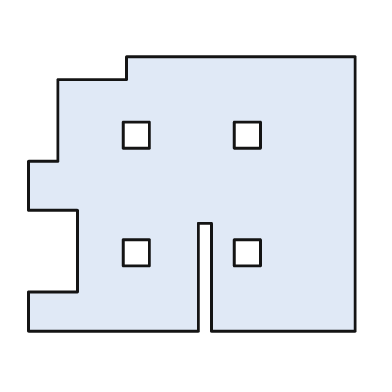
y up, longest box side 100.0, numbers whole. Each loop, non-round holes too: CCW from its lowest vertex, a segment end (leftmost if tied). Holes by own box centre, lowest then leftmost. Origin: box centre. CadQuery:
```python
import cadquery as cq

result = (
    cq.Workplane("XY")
    .moveTo(-50.0, -42.0)
    .lineTo(2.0, -42.0)
    .lineTo(2.0, -9.0)
    .lineTo(6.0, -9.0)
    .lineTo(6.0, -42.0)
    .lineTo(50.0, -42.0)
    .lineTo(50.0, 42.0)
    .lineTo(-20.0, 42.0)
    .lineTo(-20.0, 35.0)
    .lineTo(-41.0, 35.0)
    .lineTo(-41.0, 10.0)
    .lineTo(-50.0, 10.0)
    .lineTo(-50.0, -5.0)
    .lineTo(-35.0, -5.0)
    .lineTo(-35.0, -30.0)
    .lineTo(-50.0, -30.0)
    .close()
    .moveTo(-21.0, -22.0)
    .lineTo(-13.0, -22.0)
    .lineTo(-13.0, -14.0)
    .lineTo(-21.0, -14.0)
    .close()
    .moveTo(13.0, -22.0)
    .lineTo(21.0, -22.0)
    .lineTo(21.0, -14.0)
    .lineTo(13.0, -14.0)
    .close()
    .moveTo(-21.0, 14.0)
    .lineTo(-13.0, 14.0)
    .lineTo(-13.0, 22.0)
    .lineTo(-21.0, 22.0)
    .close()
    .moveTo(13.0, 14.0)
    .lineTo(21.0, 14.0)
    .lineTo(21.0, 22.0)
    .lineTo(13.0, 22.0)
    .close()
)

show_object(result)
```